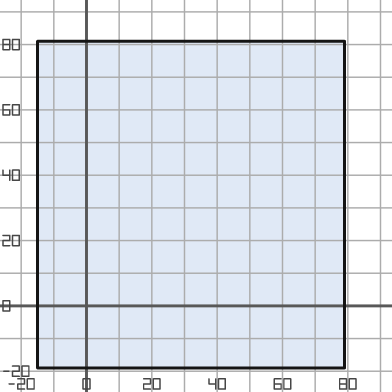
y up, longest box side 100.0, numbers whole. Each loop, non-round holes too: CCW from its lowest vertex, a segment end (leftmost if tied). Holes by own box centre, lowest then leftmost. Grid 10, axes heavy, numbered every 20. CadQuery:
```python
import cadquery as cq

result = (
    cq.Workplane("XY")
    .moveTo(-15.0, -19.0)
    .lineTo(79.0, -19.0)
    .lineTo(79.0, 81.0)
    .lineTo(-15.0, 81.0)
    .close()
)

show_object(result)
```